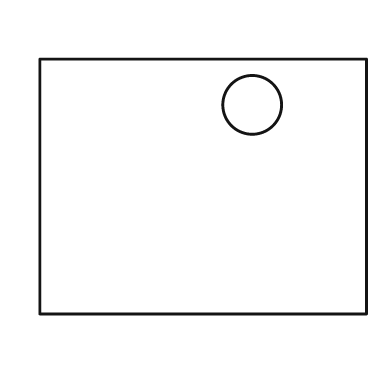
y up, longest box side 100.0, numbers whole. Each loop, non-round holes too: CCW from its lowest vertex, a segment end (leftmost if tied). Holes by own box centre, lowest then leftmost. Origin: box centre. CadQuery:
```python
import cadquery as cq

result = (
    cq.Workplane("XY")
    .moveTo(-50.0, -39.0)
    .lineTo(50.0, -39.0)
    .lineTo(50.0, 39.0)
    .lineTo(-50.0, 39.0)
    .close()
    .moveTo(15.0, 25.0)
    .circle(9.0)
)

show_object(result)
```